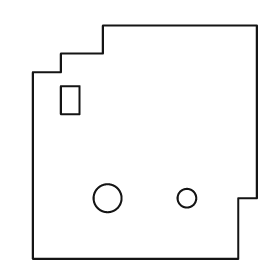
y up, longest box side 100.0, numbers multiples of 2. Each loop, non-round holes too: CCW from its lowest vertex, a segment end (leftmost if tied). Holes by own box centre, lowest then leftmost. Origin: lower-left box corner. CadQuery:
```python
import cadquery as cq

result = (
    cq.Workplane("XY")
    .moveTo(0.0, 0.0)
    .lineTo(88.0, 0.0)
    .lineTo(88.0, 26.0)
    .lineTo(96.0, 26.0)
    .lineTo(96.0, 100.0)
    .lineTo(30.0, 100.0)
    .lineTo(30.0, 88.0)
    .lineTo(12.0, 88.0)
    .lineTo(12.0, 80.0)
    .lineTo(0.0, 80.0)
    .close()
    .moveTo(32.0, 26.0)
    .circle(6.0)
    .moveTo(66.0, 26.0)
    .circle(4.0)
    .moveTo(12.0, 62.0)
    .lineTo(20.0, 62.0)
    .lineTo(20.0, 74.0)
    .lineTo(12.0, 74.0)
    .close()
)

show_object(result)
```